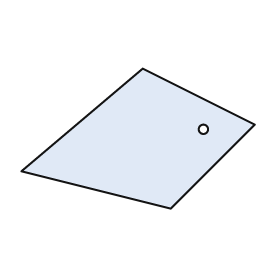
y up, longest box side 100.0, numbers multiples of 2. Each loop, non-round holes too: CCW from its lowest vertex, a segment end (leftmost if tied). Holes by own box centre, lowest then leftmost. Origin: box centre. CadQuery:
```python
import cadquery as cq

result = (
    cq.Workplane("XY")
    .moveTo(14.0, -30.0)
    .lineTo(50.0, 6.0)
    .lineTo(2.0, 30.0)
    .lineTo(-50.0, -14.0)
    .close()
    .moveTo(28.0, 4.0)
    .circle(2.0)
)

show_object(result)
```